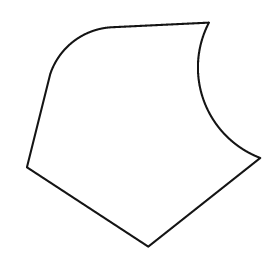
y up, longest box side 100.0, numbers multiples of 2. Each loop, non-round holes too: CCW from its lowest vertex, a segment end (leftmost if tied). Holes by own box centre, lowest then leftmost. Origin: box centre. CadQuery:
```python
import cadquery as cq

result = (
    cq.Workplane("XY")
    .moveTo(2.0, -48.0)
    .lineTo(50.0, -10.0)
    .threePointArc((26.0, 14.0), (28.0, 48.0))
    .lineTo(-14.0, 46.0)
    .threePointArc((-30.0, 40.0), (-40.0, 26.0))
    .lineTo(-50.0, -14.0)
    .close()
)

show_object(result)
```